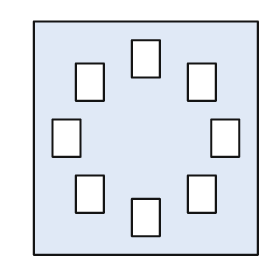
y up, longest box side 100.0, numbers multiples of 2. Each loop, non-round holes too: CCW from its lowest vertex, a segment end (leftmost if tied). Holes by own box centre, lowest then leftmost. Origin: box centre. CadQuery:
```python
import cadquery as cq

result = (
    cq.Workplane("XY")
    .moveTo(-48.0, -50.0)
    .lineTo(48.0, -50.0)
    .lineTo(48.0, 50.0)
    .lineTo(-48.0, 50.0)
    .close()
    .moveTo(-6.0, -42.0)
    .lineTo(6.0, -42.0)
    .lineTo(6.0, -26.0)
    .lineTo(-6.0, -26.0)
    .close()
    .moveTo(-30.0, -32.0)
    .lineTo(-18.0, -32.0)
    .lineTo(-18.0, -16.0)
    .lineTo(-30.0, -16.0)
    .close()
    .moveTo(18.0, -32.0)
    .lineTo(30.0, -32.0)
    .lineTo(30.0, -16.0)
    .lineTo(18.0, -16.0)
    .close()
    .moveTo(-40.0, -8.0)
    .lineTo(-28.0, -8.0)
    .lineTo(-28.0, 8.0)
    .lineTo(-40.0, 8.0)
    .close()
    .moveTo(28.0, -8.0)
    .lineTo(40.0, -8.0)
    .lineTo(40.0, 8.0)
    .lineTo(28.0, 8.0)
    .close()
    .moveTo(-30.0, 16.0)
    .lineTo(-18.0, 16.0)
    .lineTo(-18.0, 32.0)
    .lineTo(-30.0, 32.0)
    .close()
    .moveTo(18.0, 16.0)
    .lineTo(30.0, 16.0)
    .lineTo(30.0, 32.0)
    .lineTo(18.0, 32.0)
    .close()
    .moveTo(-6.0, 26.0)
    .lineTo(6.0, 26.0)
    .lineTo(6.0, 42.0)
    .lineTo(-6.0, 42.0)
    .close()
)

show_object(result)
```